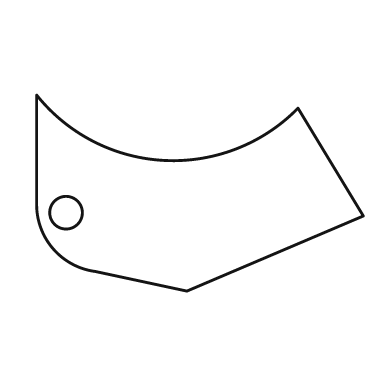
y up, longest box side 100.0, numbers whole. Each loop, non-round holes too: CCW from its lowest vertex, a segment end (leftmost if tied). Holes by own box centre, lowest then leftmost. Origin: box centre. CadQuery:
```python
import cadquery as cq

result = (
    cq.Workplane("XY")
    .moveTo(-4.0, -30.0)
    .lineTo(50.0, -7.0)
    .lineTo(30.0, 26.0)
    .threePointArc((-11.0, 10.0), (-50.0, 30.0))
    .lineTo(-50.0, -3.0)
    .threePointArc((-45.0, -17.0), (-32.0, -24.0))
    .close()
    .moveTo(-41.0, -6.0)
    .circle(5.0)
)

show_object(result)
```